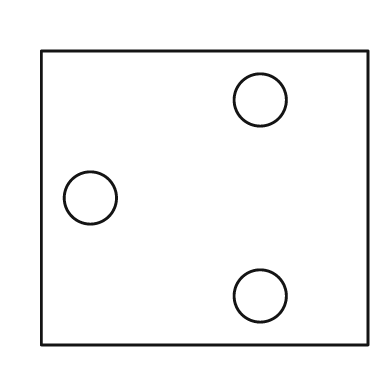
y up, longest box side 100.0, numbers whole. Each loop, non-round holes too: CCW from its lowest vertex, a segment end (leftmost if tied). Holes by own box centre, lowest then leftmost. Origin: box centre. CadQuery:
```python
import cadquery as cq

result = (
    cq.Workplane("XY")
    .moveTo(-50.0, -45.0)
    .lineTo(50.0, -45.0)
    .lineTo(50.0, 45.0)
    .lineTo(-50.0, 45.0)
    .close()
    .moveTo(17.0, -30.0)
    .circle(8.0)
    .moveTo(-35.0, 0.0)
    .circle(8.0)
    .moveTo(17.0, 30.0)
    .circle(8.0)
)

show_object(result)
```